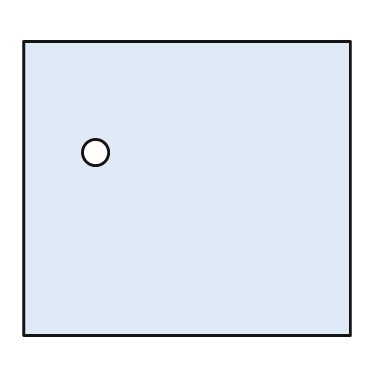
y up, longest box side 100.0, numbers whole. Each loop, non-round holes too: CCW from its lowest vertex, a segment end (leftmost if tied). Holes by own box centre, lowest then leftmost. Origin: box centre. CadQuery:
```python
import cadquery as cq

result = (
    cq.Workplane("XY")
    .moveTo(-50.0, -45.0)
    .lineTo(50.0, -45.0)
    .lineTo(50.0, 45.0)
    .lineTo(-50.0, 45.0)
    .close()
    .moveTo(-28.0, 11.0)
    .circle(4.0)
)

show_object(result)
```